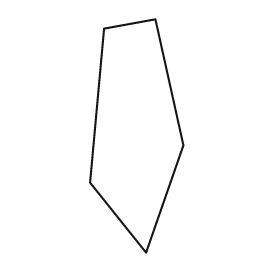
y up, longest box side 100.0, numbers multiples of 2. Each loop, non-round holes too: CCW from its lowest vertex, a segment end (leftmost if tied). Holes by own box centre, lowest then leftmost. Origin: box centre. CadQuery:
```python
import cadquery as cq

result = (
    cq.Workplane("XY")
    .moveTo(4.0, -50.0)
    .lineTo(20.0, -4.0)
    .lineTo(8.0, 50.0)
    .lineTo(-14.0, 46.0)
    .lineTo(-20.0, -20.0)
    .close()
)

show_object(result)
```